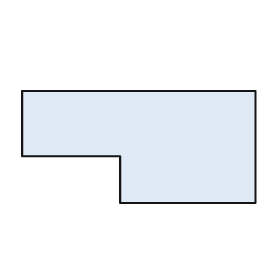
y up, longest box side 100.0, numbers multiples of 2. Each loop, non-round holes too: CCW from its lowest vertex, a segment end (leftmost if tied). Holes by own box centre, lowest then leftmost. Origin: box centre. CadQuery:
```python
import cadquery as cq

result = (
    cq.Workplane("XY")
    .moveTo(-8.0, -24.0)
    .lineTo(50.0, -24.0)
    .lineTo(50.0, 24.0)
    .lineTo(-50.0, 24.0)
    .lineTo(-50.0, -4.0)
    .lineTo(-8.0, -4.0)
    .close()
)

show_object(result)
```